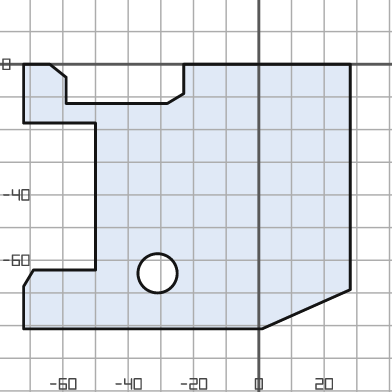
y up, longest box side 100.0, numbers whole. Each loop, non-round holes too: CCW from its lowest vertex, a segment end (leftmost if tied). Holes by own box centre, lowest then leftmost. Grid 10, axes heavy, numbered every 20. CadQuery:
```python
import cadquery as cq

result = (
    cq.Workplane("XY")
    .moveTo(-72.0, -81.0)
    .lineTo(1.0, -81.0)
    .lineTo(28.0, -69.0)
    .lineTo(28.0, 0.0)
    .lineTo(-23.0, 0.0)
    .lineTo(-23.0, -9.0)
    .lineTo(-28.0, -12.0)
    .lineTo(-59.0, -12.0)
    .lineTo(-59.0, -4.0)
    .lineTo(-64.0, 0.0)
    .lineTo(-72.0, 0.0)
    .lineTo(-72.0, -18.0)
    .lineTo(-50.0, -18.0)
    .lineTo(-50.0, -63.0)
    .lineTo(-69.0, -63.0)
    .lineTo(-72.0, -68.0)
    .close()
    .moveTo(-31.0, -64.0)
    .circle(6.0)
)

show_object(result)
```